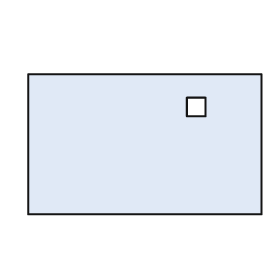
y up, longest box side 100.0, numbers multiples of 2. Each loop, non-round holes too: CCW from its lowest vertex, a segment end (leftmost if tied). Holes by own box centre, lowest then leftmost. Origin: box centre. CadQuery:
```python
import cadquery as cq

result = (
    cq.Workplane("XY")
    .moveTo(-50.0, -30.0)
    .lineTo(50.0, -30.0)
    .lineTo(50.0, 30.0)
    .lineTo(-50.0, 30.0)
    .close()
    .moveTo(18.0, 12.0)
    .lineTo(26.0, 12.0)
    .lineTo(26.0, 20.0)
    .lineTo(18.0, 20.0)
    .close()
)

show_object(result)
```